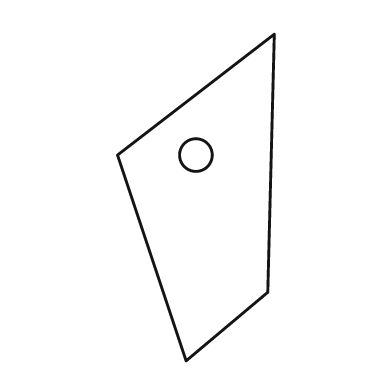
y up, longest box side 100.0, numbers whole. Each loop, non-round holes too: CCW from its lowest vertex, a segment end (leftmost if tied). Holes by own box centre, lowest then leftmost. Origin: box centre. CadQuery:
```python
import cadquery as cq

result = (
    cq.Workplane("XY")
    .moveTo(-3.0, -50.0)
    .lineTo(22.0, -29.0)
    .lineTo(24.0, 50.0)
    .lineTo(-24.0, 13.0)
    .close()
    .moveTo(0.0, 13.0)
    .circle(5.0)
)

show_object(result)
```